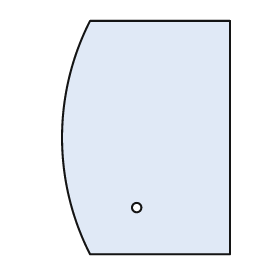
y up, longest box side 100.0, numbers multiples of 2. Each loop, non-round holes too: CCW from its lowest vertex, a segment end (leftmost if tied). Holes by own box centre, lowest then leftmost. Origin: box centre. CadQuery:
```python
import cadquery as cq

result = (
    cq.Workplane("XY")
    .moveTo(-24.0, -50.0)
    .lineTo(36.0, -50.0)
    .lineTo(36.0, 50.0)
    .lineTo(-24.0, 50.0)
    .threePointArc((-36.0, 0.0), (-24.0, -50.0))
    .close()
    .moveTo(-4.0, -30.0)
    .circle(2.0)
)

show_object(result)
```